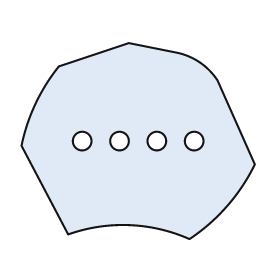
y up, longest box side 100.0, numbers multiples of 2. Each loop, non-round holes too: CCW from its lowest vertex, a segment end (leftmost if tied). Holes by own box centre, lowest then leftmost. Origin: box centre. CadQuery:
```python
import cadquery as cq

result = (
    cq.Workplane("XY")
    .moveTo(22.0, -42.0)
    .threePointArc((38.0, -28.0), (50.0, -10.0))
    .lineTo(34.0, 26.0)
    .threePointArc((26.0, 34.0), (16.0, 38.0))
    .lineTo(-4.0, 42.0)
    .lineTo(-34.0, 32.0)
    .threePointArc((-44.0, 16.0), (-50.0, -2.0))
    .lineTo(-30.0, -40.0)
    .threePointArc((-4.0, -36.0), (22.0, -42.0))
    .close()
    .moveTo(-24.0, 0.0)
    .circle(4.0)
    .moveTo(-8.0, 0.0)
    .circle(4.0)
    .moveTo(8.0, 0.0)
    .circle(4.0)
    .moveTo(24.0, 0.0)
    .circle(4.0)
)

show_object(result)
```